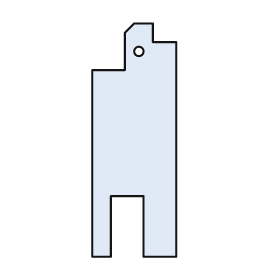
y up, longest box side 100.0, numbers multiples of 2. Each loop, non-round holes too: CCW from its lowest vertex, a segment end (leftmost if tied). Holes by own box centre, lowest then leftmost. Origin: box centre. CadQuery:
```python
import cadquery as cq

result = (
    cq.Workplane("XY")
    .moveTo(-18.0, -50.0)
    .lineTo(-10.0, -50.0)
    .lineTo(-10.0, -24.0)
    .lineTo(4.0, -24.0)
    .lineTo(4.0, -50.0)
    .lineTo(18.0, -50.0)
    .lineTo(18.0, 42.0)
    .lineTo(8.0, 42.0)
    .lineTo(8.0, 50.0)
    .lineTo(0.0, 50.0)
    .lineTo(-4.0, 46.0)
    .lineTo(-4.0, 30.0)
    .lineTo(-18.0, 30.0)
    .close()
    .moveTo(2.0, 38.0)
    .circle(2.0)
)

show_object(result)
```